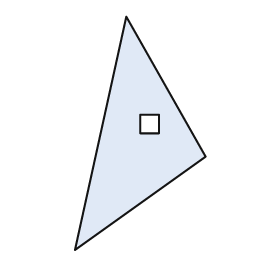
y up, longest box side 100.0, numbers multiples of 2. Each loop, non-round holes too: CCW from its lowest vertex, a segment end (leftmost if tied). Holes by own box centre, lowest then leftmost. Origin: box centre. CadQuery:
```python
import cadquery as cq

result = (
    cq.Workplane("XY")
    .moveTo(-28.0, -50.0)
    .lineTo(28.0, -10.0)
    .lineTo(-6.0, 50.0)
    .close()
    .moveTo(0.0, 0.0)
    .lineTo(8.0, 0.0)
    .lineTo(8.0, 8.0)
    .lineTo(0.0, 8.0)
    .close()
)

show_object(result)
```